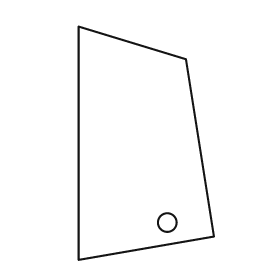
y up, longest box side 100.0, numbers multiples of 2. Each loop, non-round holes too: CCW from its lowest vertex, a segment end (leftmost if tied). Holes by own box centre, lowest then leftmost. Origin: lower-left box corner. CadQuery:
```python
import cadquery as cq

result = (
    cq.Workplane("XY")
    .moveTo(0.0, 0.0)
    .lineTo(58.0, 10.0)
    .lineTo(46.0, 86.0)
    .lineTo(0.0, 100.0)
    .close()
    .moveTo(38.0, 16.0)
    .circle(4.0)
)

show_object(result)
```